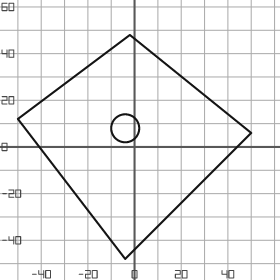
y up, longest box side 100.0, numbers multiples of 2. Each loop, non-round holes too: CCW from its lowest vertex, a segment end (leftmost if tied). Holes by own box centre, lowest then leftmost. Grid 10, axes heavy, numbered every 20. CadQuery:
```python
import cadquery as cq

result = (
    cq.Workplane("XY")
    .moveTo(-4.0, -48.0)
    .lineTo(50.0, 6.0)
    .lineTo(-2.0, 48.0)
    .lineTo(-50.0, 12.0)
    .close()
    .moveTo(-4.0, 8.0)
    .circle(6.0)
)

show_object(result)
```